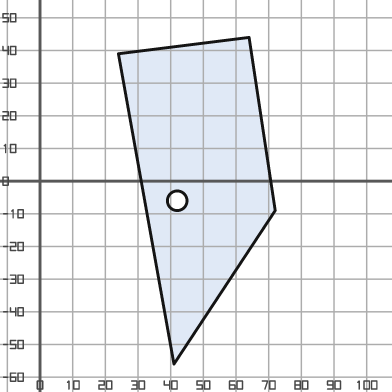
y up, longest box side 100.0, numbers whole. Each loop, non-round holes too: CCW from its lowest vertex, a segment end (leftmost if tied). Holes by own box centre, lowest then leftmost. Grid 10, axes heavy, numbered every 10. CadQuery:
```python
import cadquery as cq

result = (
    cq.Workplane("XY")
    .moveTo(41.0, -56.0)
    .lineTo(72.0, -9.0)
    .lineTo(64.0, 44.0)
    .lineTo(24.0, 39.0)
    .close()
    .moveTo(42.0, -6.0)
    .circle(3.0)
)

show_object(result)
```